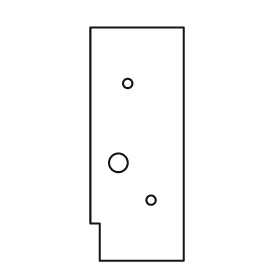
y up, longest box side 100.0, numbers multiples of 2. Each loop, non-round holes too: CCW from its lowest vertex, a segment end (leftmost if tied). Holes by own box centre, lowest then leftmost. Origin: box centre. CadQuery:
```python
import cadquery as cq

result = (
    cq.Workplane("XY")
    .moveTo(-16.0, -50.0)
    .lineTo(20.0, -50.0)
    .lineTo(20.0, 50.0)
    .lineTo(-20.0, 50.0)
    .lineTo(-20.0, -34.0)
    .lineTo(-16.0, -34.0)
    .close()
    .moveTo(6.0, -24.0)
    .circle(2.0)
    .moveTo(-8.0, -8.0)
    .circle(4.0)
    .moveTo(-4.0, 26.0)
    .circle(2.0)
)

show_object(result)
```